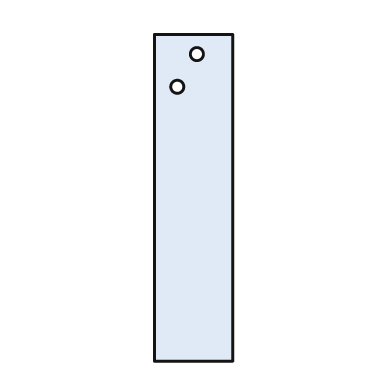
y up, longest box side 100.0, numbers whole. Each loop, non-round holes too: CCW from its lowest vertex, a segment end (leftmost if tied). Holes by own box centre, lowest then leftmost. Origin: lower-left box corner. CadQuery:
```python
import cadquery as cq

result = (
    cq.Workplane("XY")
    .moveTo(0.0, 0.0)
    .lineTo(24.0, 0.0)
    .lineTo(24.0, 100.0)
    .lineTo(0.0, 100.0)
    .close()
    .moveTo(7.0, 84.0)
    .circle(2.0)
    .moveTo(13.0, 94.0)
    .circle(2.0)
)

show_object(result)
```